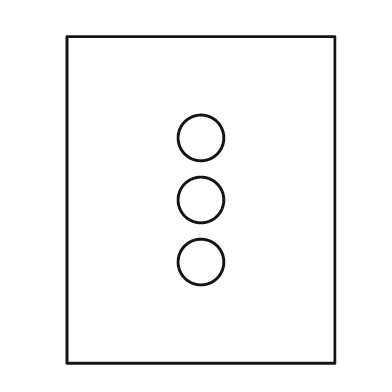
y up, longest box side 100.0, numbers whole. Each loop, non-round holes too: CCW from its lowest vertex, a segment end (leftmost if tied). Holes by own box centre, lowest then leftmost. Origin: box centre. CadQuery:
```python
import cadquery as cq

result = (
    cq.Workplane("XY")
    .moveTo(-41.0, -50.0)
    .lineTo(41.0, -50.0)
    .lineTo(41.0, 50.0)
    .lineTo(-41.0, 50.0)
    .close()
    .moveTo(0.0, -19.0)
    .circle(7.0)
    .moveTo(0.0, 0.0)
    .circle(7.0)
    .moveTo(0.0, 19.0)
    .circle(7.0)
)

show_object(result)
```